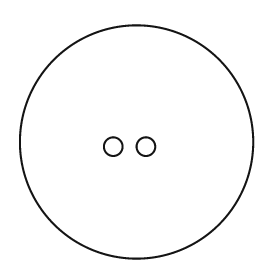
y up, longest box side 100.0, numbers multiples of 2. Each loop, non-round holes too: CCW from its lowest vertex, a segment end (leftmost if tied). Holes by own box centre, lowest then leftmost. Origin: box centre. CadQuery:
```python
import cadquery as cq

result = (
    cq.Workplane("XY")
    .moveTo(0.0, 0.0)
    .circle(50.0)
    .moveTo(-10.0, -2.0)
    .circle(4.0)
    .moveTo(4.0, -2.0)
    .circle(4.0)
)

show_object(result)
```